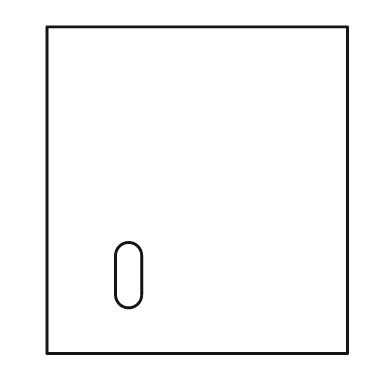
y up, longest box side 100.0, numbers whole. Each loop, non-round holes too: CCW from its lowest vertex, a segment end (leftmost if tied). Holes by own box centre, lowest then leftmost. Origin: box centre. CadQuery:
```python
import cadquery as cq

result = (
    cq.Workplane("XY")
    .moveTo(-46.0, -50.0)
    .lineTo(46.0, -50.0)
    .lineTo(46.0, 50.0)
    .lineTo(-46.0, 50.0)
    .close()
    .moveTo(-25.0, -32.0)
    .threePointArc((-21.0, -36.0), (-17.0, -32.0))
    .lineTo(-17.0, -20.0)
    .threePointArc((-21.0, -16.0), (-25.0, -20.0))
    .close()
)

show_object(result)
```